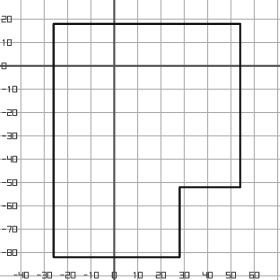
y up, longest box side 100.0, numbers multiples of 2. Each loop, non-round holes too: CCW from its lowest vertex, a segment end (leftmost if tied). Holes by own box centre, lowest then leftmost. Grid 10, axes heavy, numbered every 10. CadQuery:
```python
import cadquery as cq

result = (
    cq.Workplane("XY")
    .moveTo(-26.0, -82.0)
    .lineTo(28.0, -82.0)
    .lineTo(28.0, -52.0)
    .lineTo(54.0, -52.0)
    .lineTo(54.0, 18.0)
    .lineTo(-26.0, 18.0)
    .close()
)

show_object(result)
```